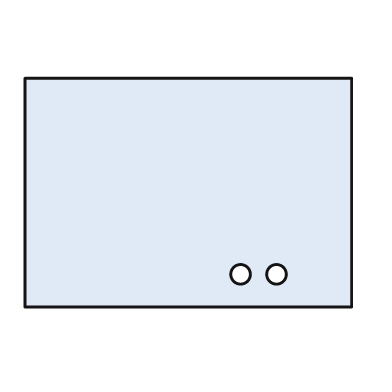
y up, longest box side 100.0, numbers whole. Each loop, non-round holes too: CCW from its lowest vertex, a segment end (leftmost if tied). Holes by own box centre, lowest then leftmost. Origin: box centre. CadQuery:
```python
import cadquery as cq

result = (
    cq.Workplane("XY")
    .moveTo(-50.0, -35.0)
    .lineTo(50.0, -35.0)
    .lineTo(50.0, 35.0)
    .lineTo(-50.0, 35.0)
    .close()
    .moveTo(16.0, -25.0)
    .circle(3.0)
    .moveTo(27.0, -25.0)
    .circle(3.0)
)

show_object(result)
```